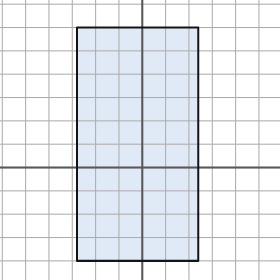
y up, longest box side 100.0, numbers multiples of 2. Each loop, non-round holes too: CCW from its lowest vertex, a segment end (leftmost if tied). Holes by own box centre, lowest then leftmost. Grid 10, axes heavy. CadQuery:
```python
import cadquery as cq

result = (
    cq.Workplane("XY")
    .moveTo(-28.0, -40.0)
    .lineTo(24.0, -40.0)
    .lineTo(24.0, 60.0)
    .lineTo(-28.0, 60.0)
    .close()
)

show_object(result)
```